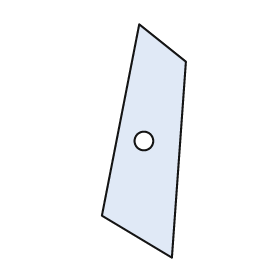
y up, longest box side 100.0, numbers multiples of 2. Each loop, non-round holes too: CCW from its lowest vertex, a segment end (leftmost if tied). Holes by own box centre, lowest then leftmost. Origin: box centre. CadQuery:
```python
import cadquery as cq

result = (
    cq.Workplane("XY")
    .moveTo(12.0, -50.0)
    .lineTo(18.0, 34.0)
    .lineTo(-2.0, 50.0)
    .lineTo(-18.0, -32.0)
    .close()
    .moveTo(0.0, 0.0)
    .circle(4.0)
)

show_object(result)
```